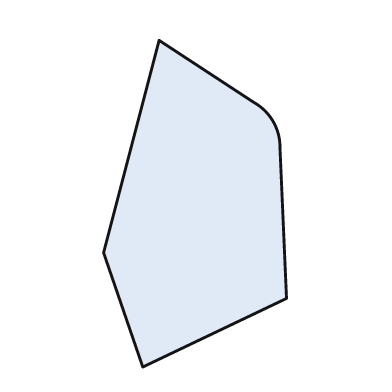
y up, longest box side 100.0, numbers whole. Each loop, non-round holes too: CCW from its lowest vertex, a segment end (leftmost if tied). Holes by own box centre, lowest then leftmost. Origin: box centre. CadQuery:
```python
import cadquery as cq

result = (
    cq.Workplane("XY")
    .moveTo(-16.0, -50.0)
    .lineTo(28.0, -29.0)
    .lineTo(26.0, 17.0)
    .threePointArc((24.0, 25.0), (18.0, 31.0))
    .lineTo(-11.0, 50.0)
    .lineTo(-28.0, -15.0)
    .close()
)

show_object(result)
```